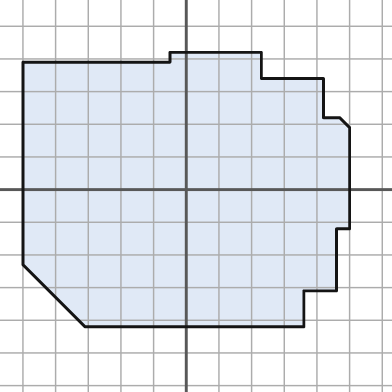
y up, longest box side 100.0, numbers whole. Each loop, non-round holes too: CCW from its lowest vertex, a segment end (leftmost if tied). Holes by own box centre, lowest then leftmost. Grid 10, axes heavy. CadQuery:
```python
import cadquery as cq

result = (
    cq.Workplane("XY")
    .moveTo(-31.0, -42.0)
    .lineTo(36.0, -42.0)
    .lineTo(36.0, -31.0)
    .lineTo(46.0, -31.0)
    .lineTo(46.0, -12.0)
    .lineTo(50.0, -12.0)
    .lineTo(50.0, 19.0)
    .lineTo(47.0, 22.0)
    .lineTo(42.0, 22.0)
    .lineTo(42.0, 34.0)
    .lineTo(23.0, 34.0)
    .lineTo(23.0, 42.0)
    .lineTo(-5.0, 42.0)
    .lineTo(-5.0, 39.0)
    .lineTo(-50.0, 39.0)
    .lineTo(-50.0, -23.0)
    .close()
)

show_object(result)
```